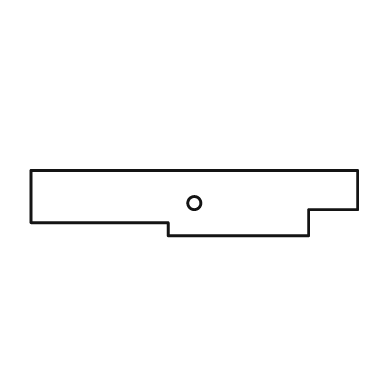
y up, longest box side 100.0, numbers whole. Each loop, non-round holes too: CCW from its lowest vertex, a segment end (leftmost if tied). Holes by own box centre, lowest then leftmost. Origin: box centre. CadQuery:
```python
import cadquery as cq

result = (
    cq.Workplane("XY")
    .moveTo(-8.0, -10.0)
    .lineTo(35.0, -10.0)
    .lineTo(35.0, -2.0)
    .lineTo(50.0, -2.0)
    .lineTo(50.0, 10.0)
    .lineTo(-50.0, 10.0)
    .lineTo(-50.0, -6.0)
    .lineTo(-8.0, -6.0)
    .close()
    .moveTo(0.0, 0.0)
    .circle(2.0)
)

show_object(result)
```